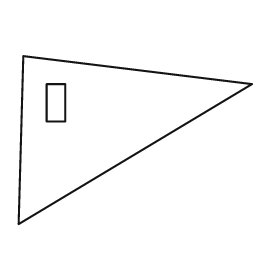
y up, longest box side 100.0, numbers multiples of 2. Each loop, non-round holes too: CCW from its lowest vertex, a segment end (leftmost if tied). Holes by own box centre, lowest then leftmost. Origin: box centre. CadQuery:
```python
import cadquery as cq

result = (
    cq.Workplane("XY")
    .moveTo(-50.0, -36.0)
    .lineTo(50.0, 24.0)
    .lineTo(-48.0, 36.0)
    .close()
    .moveTo(-38.0, 8.0)
    .lineTo(-30.0, 8.0)
    .lineTo(-30.0, 24.0)
    .lineTo(-38.0, 24.0)
    .close()
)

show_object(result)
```